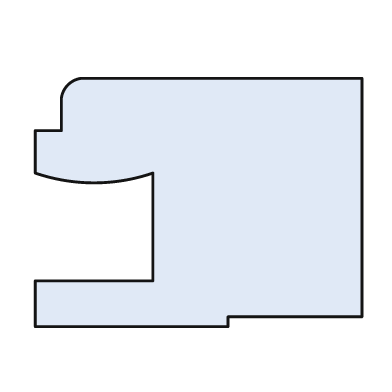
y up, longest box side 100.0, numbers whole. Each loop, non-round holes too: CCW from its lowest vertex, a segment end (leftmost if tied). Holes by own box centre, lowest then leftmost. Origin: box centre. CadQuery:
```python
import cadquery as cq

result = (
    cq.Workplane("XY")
    .moveTo(-50.0, -38.0)
    .lineTo(9.0, -38.0)
    .lineTo(9.0, -35.0)
    .lineTo(50.0, -35.0)
    .lineTo(50.0, 38.0)
    .lineTo(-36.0, 38.0)
    .threePointArc((-40.0, 36.0), (-42.0, 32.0))
    .lineTo(-42.0, 22.0)
    .lineTo(-50.0, 22.0)
    .lineTo(-50.0, 9.0)
    .threePointArc((-32.0, 6.0), (-14.0, 9.0))
    .lineTo(-14.0, -24.0)
    .lineTo(-50.0, -24.0)
    .close()
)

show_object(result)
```